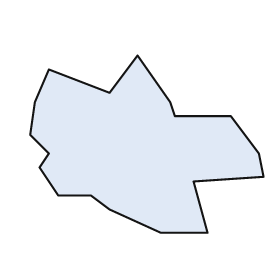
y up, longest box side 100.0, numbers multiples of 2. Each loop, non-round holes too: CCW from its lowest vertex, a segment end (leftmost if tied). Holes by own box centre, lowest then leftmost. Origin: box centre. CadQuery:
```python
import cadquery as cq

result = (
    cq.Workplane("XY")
    .moveTo(6.0, -38.0)
    .lineTo(26.0, -38.0)
    .lineTo(20.0, -16.0)
    .lineTo(50.0, -14.0)
    .lineTo(48.0, -4.0)
    .lineTo(36.0, 12.0)
    .lineTo(12.0, 12.0)
    .lineTo(10.0, 18.0)
    .lineTo(-4.0, 38.0)
    .lineTo(-16.0, 22.0)
    .lineTo(-42.0, 32.0)
    .lineTo(-48.0, 18.0)
    .lineTo(-50.0, 4.0)
    .lineTo(-42.0, -4.0)
    .lineTo(-46.0, -10.0)
    .lineTo(-38.0, -22.0)
    .lineTo(-24.0, -22.0)
    .lineTo(-16.0, -28.0)
    .close()
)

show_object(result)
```